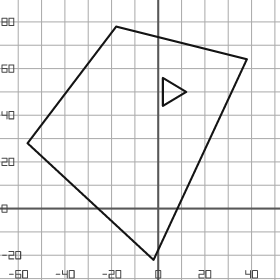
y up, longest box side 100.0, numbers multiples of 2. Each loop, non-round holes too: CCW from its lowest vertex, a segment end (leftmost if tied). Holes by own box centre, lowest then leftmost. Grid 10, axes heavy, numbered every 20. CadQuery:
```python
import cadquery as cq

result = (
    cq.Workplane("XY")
    .moveTo(-2.0, -22.0)
    .lineTo(38.0, 64.0)
    .lineTo(-18.0, 78.0)
    .lineTo(-56.0, 28.0)
    .close()
    .moveTo(2.0, 44.0)
    .lineTo(12.0, 50.0)
    .lineTo(2.0, 56.0)
    .close()
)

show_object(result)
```